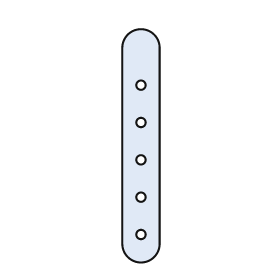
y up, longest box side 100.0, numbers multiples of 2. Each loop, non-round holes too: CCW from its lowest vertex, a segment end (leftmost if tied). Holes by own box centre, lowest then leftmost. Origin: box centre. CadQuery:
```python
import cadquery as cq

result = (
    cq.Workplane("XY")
    .moveTo(-8.0, -42.0)
    .threePointArc((0.0, -50.0), (8.0, -42.0))
    .lineTo(8.0, 42.0)
    .threePointArc((0.0, 50.0), (-8.0, 42.0))
    .close()
    .moveTo(0.0, -38.0)
    .circle(2.0)
    .moveTo(0.0, -22.0)
    .circle(2.0)
    .moveTo(0.0, -6.0)
    .circle(2.0)
    .moveTo(0.0, 10.0)
    .circle(2.0)
    .moveTo(0.0, 26.0)
    .circle(2.0)
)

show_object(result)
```